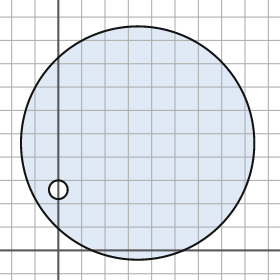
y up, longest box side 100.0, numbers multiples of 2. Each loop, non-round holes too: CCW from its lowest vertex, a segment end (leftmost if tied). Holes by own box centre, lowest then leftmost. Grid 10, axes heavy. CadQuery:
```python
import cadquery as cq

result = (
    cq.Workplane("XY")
    .moveTo(34.0, 46.0)
    .circle(50.0)
    .moveTo(0.0, 26.0)
    .circle(4.0)
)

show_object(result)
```